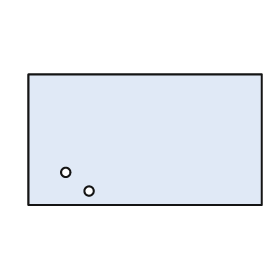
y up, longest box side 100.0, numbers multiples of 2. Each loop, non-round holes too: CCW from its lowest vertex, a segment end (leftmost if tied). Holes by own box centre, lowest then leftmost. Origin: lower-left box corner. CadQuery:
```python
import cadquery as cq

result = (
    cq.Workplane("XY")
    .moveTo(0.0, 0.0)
    .lineTo(100.0, 0.0)
    .lineTo(100.0, 56.0)
    .lineTo(0.0, 56.0)
    .close()
    .moveTo(26.0, 6.0)
    .circle(2.0)
    .moveTo(16.0, 14.0)
    .circle(2.0)
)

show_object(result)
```